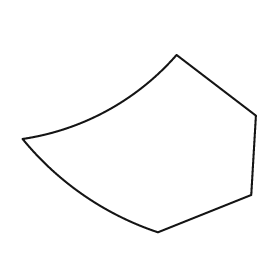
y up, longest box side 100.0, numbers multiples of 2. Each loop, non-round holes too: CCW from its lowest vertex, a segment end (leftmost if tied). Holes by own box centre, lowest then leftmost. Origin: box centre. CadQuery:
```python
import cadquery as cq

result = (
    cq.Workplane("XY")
    .moveTo(8.0, -38.0)
    .lineTo(48.0, -22.0)
    .lineTo(50.0, 12.0)
    .lineTo(16.0, 38.0)
    .threePointArc((-14.0, 14.0), (-50.0, 2.0))
    .threePointArc((-24.0, -22.0), (8.0, -38.0))
    .close()
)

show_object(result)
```